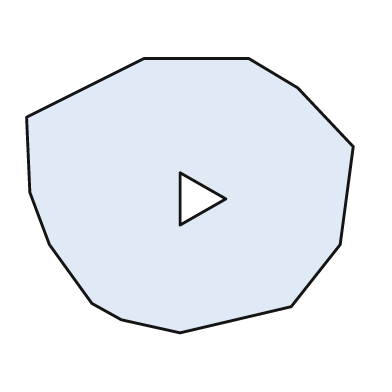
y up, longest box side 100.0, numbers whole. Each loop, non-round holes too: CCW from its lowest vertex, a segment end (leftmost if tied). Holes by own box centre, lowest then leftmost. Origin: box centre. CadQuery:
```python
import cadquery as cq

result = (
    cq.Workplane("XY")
    .moveTo(-3.0, -42.0)
    .lineTo(31.0, -34.0)
    .lineTo(46.0, -15.0)
    .lineTo(50.0, 15.0)
    .lineTo(33.0, 33.0)
    .lineTo(18.0, 42.0)
    .lineTo(-14.0, 42.0)
    .lineTo(-50.0, 24.0)
    .lineTo(-49.0, 1.0)
    .lineTo(-43.0, -15.0)
    .lineTo(-30.0, -33.0)
    .lineTo(-21.0, -38.0)
    .close()
    .moveTo(-3.0, -9.0)
    .lineTo(11.0, -1.0)
    .lineTo(-3.0, 7.0)
    .close()
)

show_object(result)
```